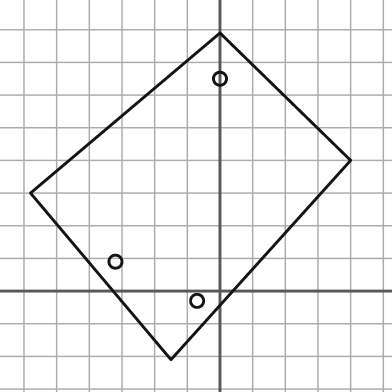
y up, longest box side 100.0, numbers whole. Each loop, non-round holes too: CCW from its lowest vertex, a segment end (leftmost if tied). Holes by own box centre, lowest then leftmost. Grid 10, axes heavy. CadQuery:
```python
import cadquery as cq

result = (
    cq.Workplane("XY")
    .moveTo(-15.0, -21.0)
    .lineTo(40.0, 40.0)
    .lineTo(0.0, 79.0)
    .lineTo(-58.0, 30.0)
    .close()
    .moveTo(-7.0, -3.0)
    .circle(2.0)
    .moveTo(-32.0, 9.0)
    .circle(2.0)
    .moveTo(0.0, 65.0)
    .circle(2.0)
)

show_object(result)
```